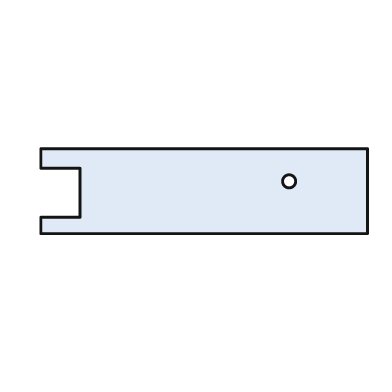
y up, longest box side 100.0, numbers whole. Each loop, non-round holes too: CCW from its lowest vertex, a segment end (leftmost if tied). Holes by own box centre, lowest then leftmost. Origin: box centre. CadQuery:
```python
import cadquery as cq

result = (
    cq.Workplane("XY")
    .moveTo(-50.0, -13.0)
    .lineTo(50.0, -13.0)
    .lineTo(50.0, 13.0)
    .lineTo(-50.0, 13.0)
    .lineTo(-50.0, 7.0)
    .lineTo(-38.0, 7.0)
    .lineTo(-38.0, -8.0)
    .lineTo(-50.0, -8.0)
    .close()
    .moveTo(26.0, 3.0)
    .circle(2.0)
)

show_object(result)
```